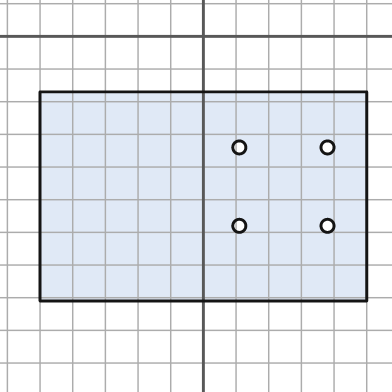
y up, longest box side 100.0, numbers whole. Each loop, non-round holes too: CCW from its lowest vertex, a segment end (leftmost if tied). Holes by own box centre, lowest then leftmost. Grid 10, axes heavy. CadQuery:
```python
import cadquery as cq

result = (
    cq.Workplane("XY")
    .moveTo(-50.0, -81.0)
    .lineTo(50.0, -81.0)
    .lineTo(50.0, -17.0)
    .lineTo(-50.0, -17.0)
    .close()
    .moveTo(11.0, -58.0)
    .circle(2.0)
    .moveTo(38.0, -58.0)
    .circle(2.0)
    .moveTo(11.0, -34.0)
    .circle(2.0)
    .moveTo(38.0, -34.0)
    .circle(2.0)
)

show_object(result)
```